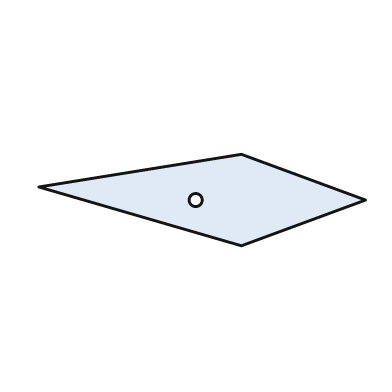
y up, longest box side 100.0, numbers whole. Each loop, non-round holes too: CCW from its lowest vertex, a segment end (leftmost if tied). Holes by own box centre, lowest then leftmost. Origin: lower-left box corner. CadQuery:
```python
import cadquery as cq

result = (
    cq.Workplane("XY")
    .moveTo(62.0, 0.0)
    .lineTo(100.0, 14.0)
    .lineTo(62.0, 28.0)
    .lineTo(0.0, 18.0)
    .close()
    .moveTo(48.0, 14.0)
    .circle(2.0)
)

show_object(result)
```